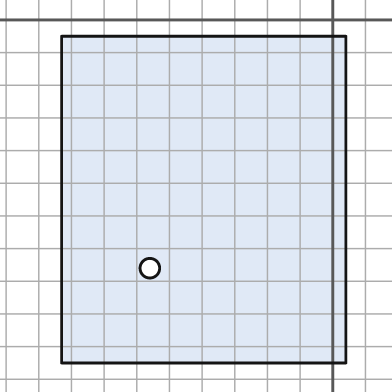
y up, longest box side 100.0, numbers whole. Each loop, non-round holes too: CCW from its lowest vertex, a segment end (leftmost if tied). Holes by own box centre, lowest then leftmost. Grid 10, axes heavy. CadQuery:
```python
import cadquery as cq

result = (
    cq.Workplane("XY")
    .moveTo(-83.0, -105.0)
    .lineTo(4.0, -105.0)
    .lineTo(4.0, -5.0)
    .lineTo(-83.0, -5.0)
    .close()
    .moveTo(-56.0, -76.0)
    .circle(3.0)
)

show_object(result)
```